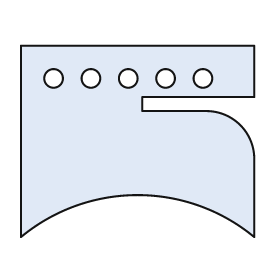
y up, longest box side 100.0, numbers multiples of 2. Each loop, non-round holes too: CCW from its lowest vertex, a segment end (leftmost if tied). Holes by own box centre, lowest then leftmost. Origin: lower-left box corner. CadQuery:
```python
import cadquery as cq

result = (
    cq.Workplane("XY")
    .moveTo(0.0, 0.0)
    .threePointArc((50.0, 18.0), (100.0, 0.0))
    .lineTo(100.0, 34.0)
    .threePointArc((94.0, 48.0), (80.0, 54.0))
    .lineTo(52.0, 54.0)
    .lineTo(52.0, 60.0)
    .lineTo(100.0, 60.0)
    .lineTo(100.0, 82.0)
    .lineTo(0.0, 82.0)
    .close()
    .moveTo(14.0, 68.0)
    .circle(4.0)
    .moveTo(30.0, 68.0)
    .circle(4.0)
    .moveTo(46.0, 68.0)
    .circle(4.0)
    .moveTo(62.0, 68.0)
    .circle(4.0)
    .moveTo(78.0, 68.0)
    .circle(4.0)
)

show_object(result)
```